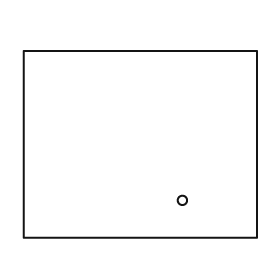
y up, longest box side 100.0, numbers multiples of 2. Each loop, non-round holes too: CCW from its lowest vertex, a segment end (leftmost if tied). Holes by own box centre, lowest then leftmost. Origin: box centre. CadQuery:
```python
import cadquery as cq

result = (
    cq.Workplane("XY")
    .moveTo(-50.0, -40.0)
    .lineTo(50.0, -40.0)
    .lineTo(50.0, 40.0)
    .lineTo(-50.0, 40.0)
    .close()
    .moveTo(18.0, -24.0)
    .circle(2.0)
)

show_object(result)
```